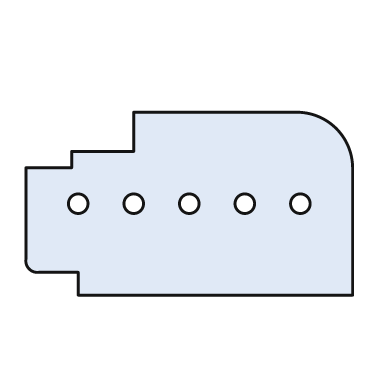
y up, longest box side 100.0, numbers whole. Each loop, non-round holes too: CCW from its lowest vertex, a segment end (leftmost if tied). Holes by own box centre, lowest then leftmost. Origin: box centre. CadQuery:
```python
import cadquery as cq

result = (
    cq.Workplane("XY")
    .moveTo(-34.0, -28.0)
    .lineTo(50.0, -28.0)
    .lineTo(50.0, 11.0)
    .threePointArc((45.0, 23.0), (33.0, 28.0))
    .lineTo(-17.0, 28.0)
    .lineTo(-17.0, 16.0)
    .lineTo(-36.0, 16.0)
    .lineTo(-36.0, 11.0)
    .lineTo(-50.0, 11.0)
    .lineTo(-50.0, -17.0)
    .threePointArc((-49.0, -20.0), (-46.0, -21.0))
    .lineTo(-34.0, -21.0)
    .close()
    .moveTo(-34.0, 0.0)
    .circle(3.0)
    .moveTo(-17.0, 0.0)
    .circle(3.0)
    .moveTo(0.0, 0.0)
    .circle(3.0)
    .moveTo(17.0, 0.0)
    .circle(3.0)
    .moveTo(34.0, 0.0)
    .circle(3.0)
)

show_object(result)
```